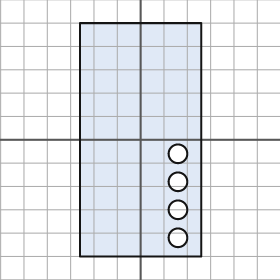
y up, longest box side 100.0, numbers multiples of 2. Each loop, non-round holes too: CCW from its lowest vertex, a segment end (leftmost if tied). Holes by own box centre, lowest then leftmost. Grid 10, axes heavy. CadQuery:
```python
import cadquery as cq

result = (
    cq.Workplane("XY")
    .moveTo(-26.0, -50.0)
    .lineTo(26.0, -50.0)
    .lineTo(26.0, 50.0)
    .lineTo(-26.0, 50.0)
    .close()
    .moveTo(16.0, -42.0)
    .circle(4.0)
    .moveTo(16.0, -30.0)
    .circle(4.0)
    .moveTo(16.0, -18.0)
    .circle(4.0)
    .moveTo(16.0, -6.0)
    .circle(4.0)
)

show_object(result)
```